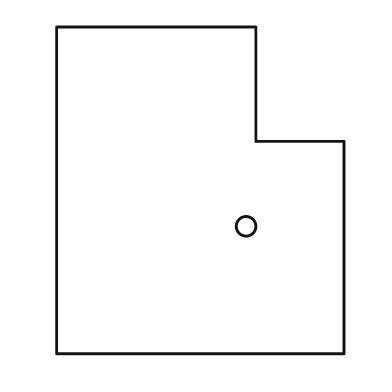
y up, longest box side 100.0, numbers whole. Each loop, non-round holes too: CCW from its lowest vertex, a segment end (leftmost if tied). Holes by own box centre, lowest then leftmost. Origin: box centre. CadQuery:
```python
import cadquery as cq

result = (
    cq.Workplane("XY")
    .moveTo(-44.0, -50.0)
    .lineTo(44.0, -50.0)
    .lineTo(44.0, 15.0)
    .lineTo(17.0, 15.0)
    .lineTo(17.0, 50.0)
    .lineTo(-44.0, 50.0)
    .close()
    .moveTo(14.0, -11.0)
    .circle(3.0)
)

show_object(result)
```